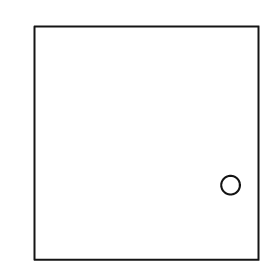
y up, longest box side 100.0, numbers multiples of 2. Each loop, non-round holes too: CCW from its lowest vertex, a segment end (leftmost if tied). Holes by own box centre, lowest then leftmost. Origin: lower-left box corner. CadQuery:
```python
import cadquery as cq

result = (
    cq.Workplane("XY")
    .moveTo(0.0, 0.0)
    .lineTo(96.0, 0.0)
    .lineTo(96.0, 100.0)
    .lineTo(0.0, 100.0)
    .close()
    .moveTo(84.0, 32.0)
    .circle(4.0)
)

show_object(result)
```